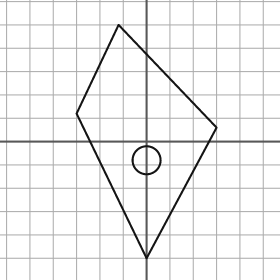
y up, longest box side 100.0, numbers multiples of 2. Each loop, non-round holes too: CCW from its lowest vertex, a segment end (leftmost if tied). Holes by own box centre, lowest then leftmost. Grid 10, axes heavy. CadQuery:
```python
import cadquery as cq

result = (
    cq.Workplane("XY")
    .moveTo(0.0, -50.0)
    .lineTo(30.0, 6.0)
    .lineTo(-12.0, 50.0)
    .lineTo(-30.0, 12.0)
    .close()
    .moveTo(0.0, -8.0)
    .circle(6.0)
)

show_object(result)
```